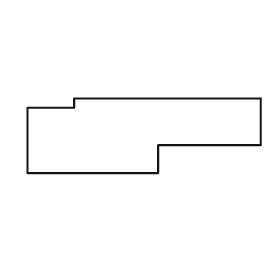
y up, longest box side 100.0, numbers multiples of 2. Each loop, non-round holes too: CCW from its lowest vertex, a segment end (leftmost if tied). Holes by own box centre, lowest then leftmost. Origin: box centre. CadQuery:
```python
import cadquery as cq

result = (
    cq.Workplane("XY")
    .moveTo(-50.0, -16.0)
    .lineTo(6.0, -16.0)
    .lineTo(6.0, -4.0)
    .lineTo(50.0, -4.0)
    .lineTo(50.0, 16.0)
    .lineTo(-30.0, 16.0)
    .lineTo(-30.0, 12.0)
    .lineTo(-50.0, 12.0)
    .close()
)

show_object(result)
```